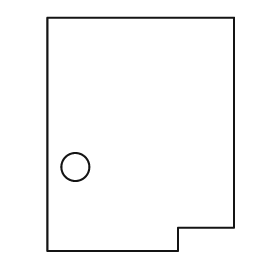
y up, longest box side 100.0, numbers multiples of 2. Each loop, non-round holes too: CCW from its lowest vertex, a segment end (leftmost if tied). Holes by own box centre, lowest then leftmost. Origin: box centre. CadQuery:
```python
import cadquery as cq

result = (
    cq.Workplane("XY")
    .moveTo(-40.0, -50.0)
    .lineTo(16.0, -50.0)
    .lineTo(16.0, -40.0)
    .lineTo(40.0, -40.0)
    .lineTo(40.0, 50.0)
    .lineTo(-40.0, 50.0)
    .close()
    .moveTo(-28.0, -14.0)
    .circle(6.0)
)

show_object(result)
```